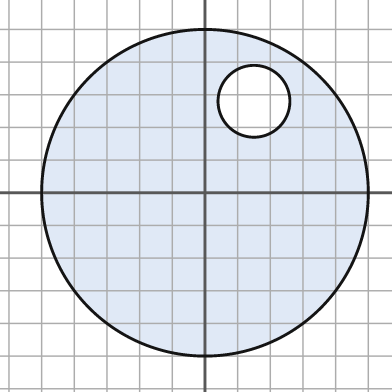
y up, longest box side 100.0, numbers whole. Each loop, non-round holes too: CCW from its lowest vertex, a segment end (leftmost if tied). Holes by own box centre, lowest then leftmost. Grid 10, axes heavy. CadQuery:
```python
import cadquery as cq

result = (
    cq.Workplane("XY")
    .moveTo(0.0, 0.0)
    .circle(50.0)
    .moveTo(15.0, 28.0)
    .circle(11.0)
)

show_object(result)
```